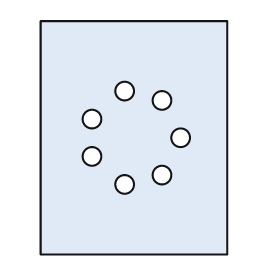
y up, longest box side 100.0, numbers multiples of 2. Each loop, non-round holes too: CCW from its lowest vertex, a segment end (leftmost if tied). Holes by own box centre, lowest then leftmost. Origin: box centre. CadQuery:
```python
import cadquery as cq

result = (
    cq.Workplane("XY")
    .moveTo(-40.0, -50.0)
    .lineTo(40.0, -50.0)
    .lineTo(40.0, 50.0)
    .lineTo(-40.0, 50.0)
    .close()
    .moveTo(-4.0, -20.0)
    .circle(4.0)
    .moveTo(12.0, -16.0)
    .circle(4.0)
    .moveTo(-18.0, -8.0)
    .circle(4.0)
    .moveTo(20.0, 0.0)
    .circle(4.0)
    .moveTo(-18.0, 8.0)
    .circle(4.0)
    .moveTo(12.0, 16.0)
    .circle(4.0)
    .moveTo(-4.0, 20.0)
    .circle(4.0)
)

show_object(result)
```